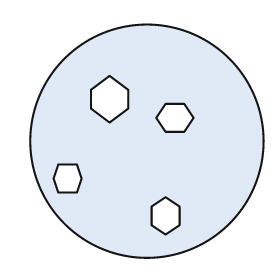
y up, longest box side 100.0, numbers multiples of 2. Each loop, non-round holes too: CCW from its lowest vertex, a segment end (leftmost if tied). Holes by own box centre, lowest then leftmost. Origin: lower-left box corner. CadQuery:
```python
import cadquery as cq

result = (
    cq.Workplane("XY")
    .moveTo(50.0, 50.0)
    .circle(50.0)
    .moveTo(58.0, 10.0)
    .lineTo(64.0, 14.0)
    .lineTo(64.0, 22.0)
    .lineTo(58.0, 26.0)
    .lineTo(52.0, 22.0)
    .lineTo(52.0, 14.0)
    .close()
    .moveTo(12.0, 28.0)
    .lineTo(20.0, 28.0)
    .lineTo(22.0, 34.0)
    .lineTo(20.0, 40.0)
    .lineTo(12.0, 40.0)
    .lineTo(10.0, 34.0)
    .close()
    .moveTo(58.0, 54.0)
    .lineTo(66.0, 54.0)
    .lineTo(70.0, 60.0)
    .lineTo(66.0, 66.0)
    .lineTo(58.0, 66.0)
    .lineTo(54.0, 60.0)
    .close()
    .moveTo(34.0, 58.0)
    .lineTo(42.0, 64.0)
    .lineTo(42.0, 72.0)
    .lineTo(34.0, 78.0)
    .lineTo(26.0, 72.0)
    .lineTo(26.0, 64.0)
    .close()
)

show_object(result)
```